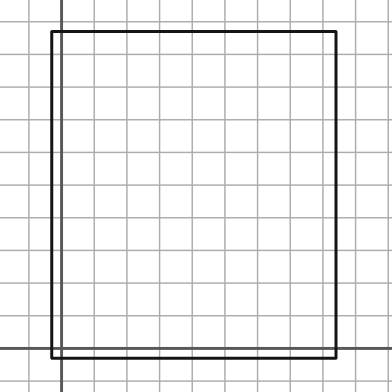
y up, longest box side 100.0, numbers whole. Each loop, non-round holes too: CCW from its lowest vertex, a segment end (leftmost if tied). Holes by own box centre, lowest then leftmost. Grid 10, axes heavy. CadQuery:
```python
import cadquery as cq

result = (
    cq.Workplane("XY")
    .moveTo(-3.0, -3.0)
    .lineTo(84.0, -3.0)
    .lineTo(84.0, 97.0)
    .lineTo(-3.0, 97.0)
    .close()
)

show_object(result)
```